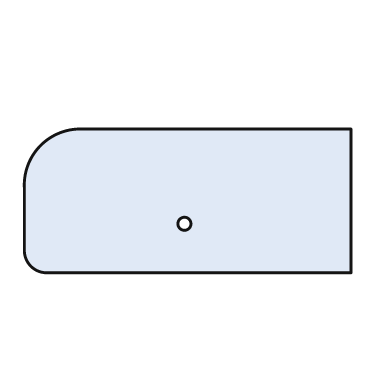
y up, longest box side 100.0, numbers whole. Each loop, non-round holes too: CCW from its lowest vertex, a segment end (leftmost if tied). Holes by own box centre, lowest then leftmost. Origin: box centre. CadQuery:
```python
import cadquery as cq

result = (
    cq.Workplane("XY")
    .moveTo(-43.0, -22.0)
    .lineTo(50.0, -22.0)
    .lineTo(50.0, 22.0)
    .lineTo(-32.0, 22.0)
    .threePointArc((-45.0, 17.0), (-50.0, 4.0))
    .lineTo(-50.0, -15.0)
    .threePointArc((-48.0, -20.0), (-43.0, -22.0))
    .close()
    .moveTo(-1.0, -7.0)
    .circle(2.0)
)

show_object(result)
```